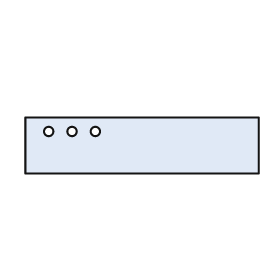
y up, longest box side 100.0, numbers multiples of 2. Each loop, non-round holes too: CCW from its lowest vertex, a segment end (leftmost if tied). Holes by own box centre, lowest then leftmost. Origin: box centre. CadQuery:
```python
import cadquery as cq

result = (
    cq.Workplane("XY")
    .moveTo(-50.0, -12.0)
    .lineTo(50.0, -12.0)
    .lineTo(50.0, 12.0)
    .lineTo(-50.0, 12.0)
    .close()
    .moveTo(-40.0, 6.0)
    .circle(2.0)
    .moveTo(-30.0, 6.0)
    .circle(2.0)
    .moveTo(-20.0, 6.0)
    .circle(2.0)
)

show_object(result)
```